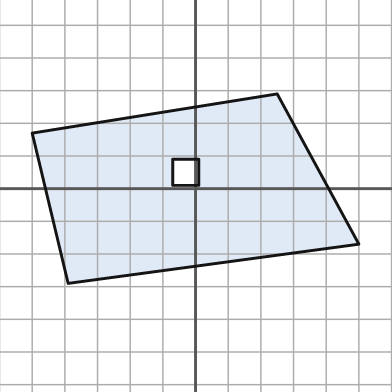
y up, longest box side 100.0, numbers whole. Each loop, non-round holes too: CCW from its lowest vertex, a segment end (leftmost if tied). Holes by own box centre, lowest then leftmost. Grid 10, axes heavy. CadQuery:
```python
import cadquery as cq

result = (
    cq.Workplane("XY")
    .moveTo(-39.0, -29.0)
    .lineTo(50.0, -17.0)
    .lineTo(25.0, 29.0)
    .lineTo(-50.0, 17.0)
    .close()
    .moveTo(-7.0, 1.0)
    .lineTo(1.0, 1.0)
    .lineTo(1.0, 9.0)
    .lineTo(-7.0, 9.0)
    .close()
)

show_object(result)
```